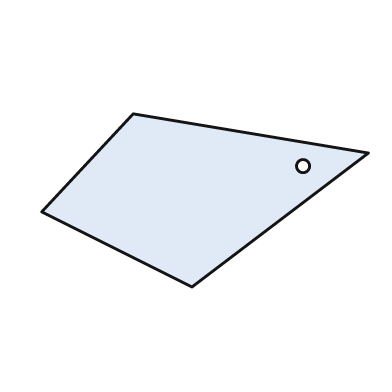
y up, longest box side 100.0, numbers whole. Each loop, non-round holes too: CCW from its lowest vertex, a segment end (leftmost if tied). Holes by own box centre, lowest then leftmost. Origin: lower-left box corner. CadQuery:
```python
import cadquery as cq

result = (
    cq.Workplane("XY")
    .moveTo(46.0, 0.0)
    .lineTo(100.0, 41.0)
    .lineTo(28.0, 53.0)
    .lineTo(0.0, 23.0)
    .close()
    .moveTo(80.0, 37.0)
    .circle(2.0)
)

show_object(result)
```